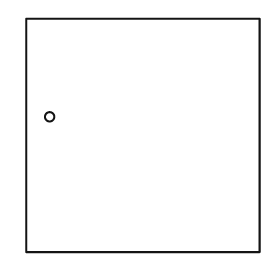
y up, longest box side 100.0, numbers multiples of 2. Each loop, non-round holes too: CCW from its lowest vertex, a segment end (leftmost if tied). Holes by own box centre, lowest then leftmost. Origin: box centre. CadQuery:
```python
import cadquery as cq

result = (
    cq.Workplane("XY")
    .moveTo(-50.0, -50.0)
    .lineTo(50.0, -50.0)
    .lineTo(50.0, 50.0)
    .lineTo(-50.0, 50.0)
    .close()
    .moveTo(-40.0, 8.0)
    .circle(2.0)
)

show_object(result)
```